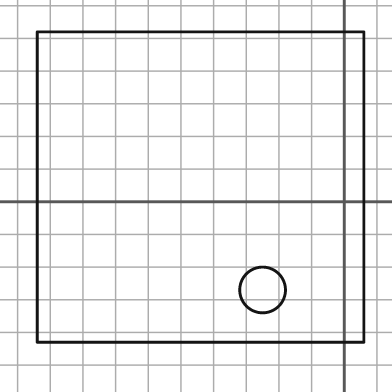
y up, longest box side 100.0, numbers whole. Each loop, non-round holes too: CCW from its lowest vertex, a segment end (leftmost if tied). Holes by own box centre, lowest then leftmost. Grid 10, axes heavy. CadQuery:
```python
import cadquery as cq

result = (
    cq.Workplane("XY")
    .moveTo(-94.0, -43.0)
    .lineTo(6.0, -43.0)
    .lineTo(6.0, 52.0)
    .lineTo(-94.0, 52.0)
    .close()
    .moveTo(-25.0, -27.0)
    .circle(7.0)
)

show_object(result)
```